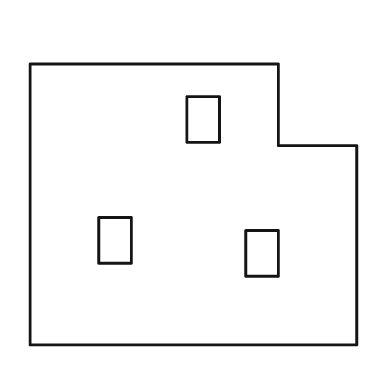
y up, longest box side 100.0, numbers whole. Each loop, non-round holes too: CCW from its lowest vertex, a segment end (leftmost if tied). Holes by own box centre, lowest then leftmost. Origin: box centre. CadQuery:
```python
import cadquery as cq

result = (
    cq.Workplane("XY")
    .moveTo(-50.0, -43.0)
    .lineTo(50.0, -43.0)
    .lineTo(50.0, 18.0)
    .lineTo(26.0, 18.0)
    .lineTo(26.0, 43.0)
    .lineTo(-50.0, 43.0)
    .close()
    .moveTo(16.0, -22.0)
    .lineTo(26.0, -22.0)
    .lineTo(26.0, -8.0)
    .lineTo(16.0, -8.0)
    .close()
    .moveTo(-29.0, -18.0)
    .lineTo(-19.0, -18.0)
    .lineTo(-19.0, -4.0)
    .lineTo(-29.0, -4.0)
    .close()
    .moveTo(-2.0, 19.0)
    .lineTo(8.0, 19.0)
    .lineTo(8.0, 33.0)
    .lineTo(-2.0, 33.0)
    .close()
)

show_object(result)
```